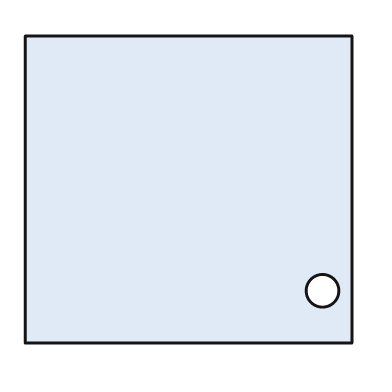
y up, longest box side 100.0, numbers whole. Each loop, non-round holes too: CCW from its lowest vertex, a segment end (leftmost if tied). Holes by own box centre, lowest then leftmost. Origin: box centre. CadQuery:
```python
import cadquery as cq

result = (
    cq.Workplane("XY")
    .moveTo(-50.0, -47.0)
    .lineTo(50.0, -47.0)
    .lineTo(50.0, 47.0)
    .lineTo(-50.0, 47.0)
    .close()
    .moveTo(41.0, -31.0)
    .circle(5.0)
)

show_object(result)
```